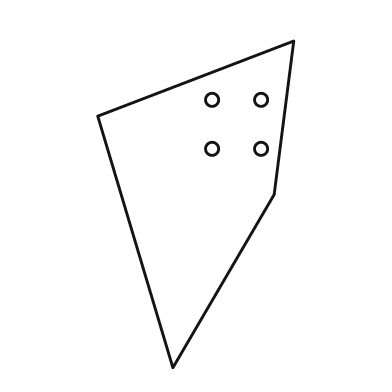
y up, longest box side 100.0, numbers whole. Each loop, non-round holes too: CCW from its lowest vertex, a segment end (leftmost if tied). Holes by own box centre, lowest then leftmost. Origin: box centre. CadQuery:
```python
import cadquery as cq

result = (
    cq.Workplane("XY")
    .moveTo(-7.0, -50.0)
    .lineTo(24.0, 3.0)
    .lineTo(30.0, 50.0)
    .lineTo(-30.0, 27.0)
    .close()
    .moveTo(5.0, 17.0)
    .circle(2.0)
    .moveTo(20.0, 17.0)
    .circle(2.0)
    .moveTo(5.0, 32.0)
    .circle(2.0)
    .moveTo(20.0, 32.0)
    .circle(2.0)
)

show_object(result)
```